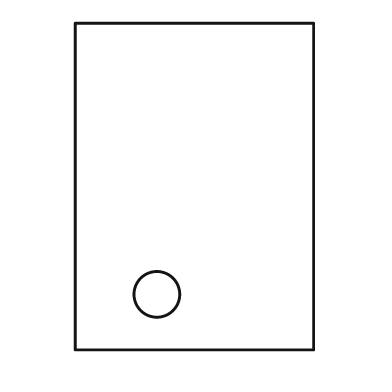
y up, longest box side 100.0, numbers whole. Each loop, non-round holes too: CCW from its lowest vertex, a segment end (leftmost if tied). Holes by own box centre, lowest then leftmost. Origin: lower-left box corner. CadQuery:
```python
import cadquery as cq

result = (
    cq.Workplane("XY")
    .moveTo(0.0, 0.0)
    .lineTo(73.0, 0.0)
    .lineTo(73.0, 100.0)
    .lineTo(0.0, 100.0)
    .close()
    .moveTo(25.0, 17.0)
    .circle(7.0)
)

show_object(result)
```